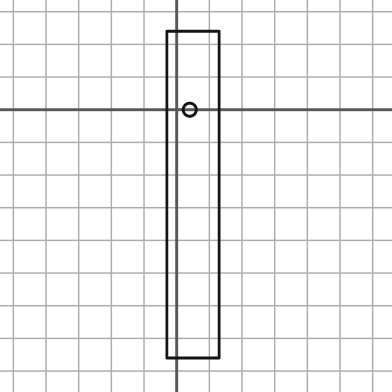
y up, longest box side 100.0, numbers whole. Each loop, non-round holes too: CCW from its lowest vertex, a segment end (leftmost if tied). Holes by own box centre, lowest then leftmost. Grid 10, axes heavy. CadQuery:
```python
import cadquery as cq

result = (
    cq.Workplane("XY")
    .moveTo(-3.0, -76.0)
    .lineTo(13.0, -76.0)
    .lineTo(13.0, 24.0)
    .lineTo(-3.0, 24.0)
    .close()
    .moveTo(4.0, 0.0)
    .circle(2.0)
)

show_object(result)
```